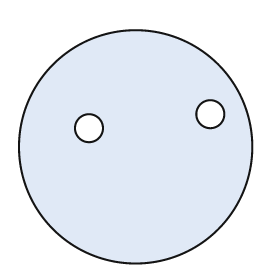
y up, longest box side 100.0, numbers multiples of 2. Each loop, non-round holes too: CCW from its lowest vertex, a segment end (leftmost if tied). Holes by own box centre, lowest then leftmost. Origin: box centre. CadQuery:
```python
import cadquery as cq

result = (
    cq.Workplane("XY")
    .moveTo(0.0, 0.0)
    .circle(50.0)
    .moveTo(-20.0, 8.0)
    .circle(6.0)
    .moveTo(32.0, 14.0)
    .circle(6.0)
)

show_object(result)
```